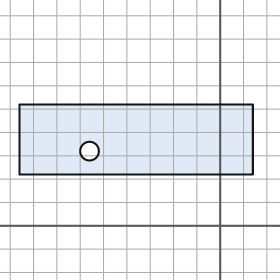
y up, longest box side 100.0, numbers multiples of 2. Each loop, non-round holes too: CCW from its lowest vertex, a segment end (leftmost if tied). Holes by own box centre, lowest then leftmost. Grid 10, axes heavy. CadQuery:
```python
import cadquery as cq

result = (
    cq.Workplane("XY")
    .moveTo(-86.0, 22.0)
    .lineTo(14.0, 22.0)
    .lineTo(14.0, 52.0)
    .lineTo(-86.0, 52.0)
    .close()
    .moveTo(-56.0, 32.0)
    .circle(4.0)
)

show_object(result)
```